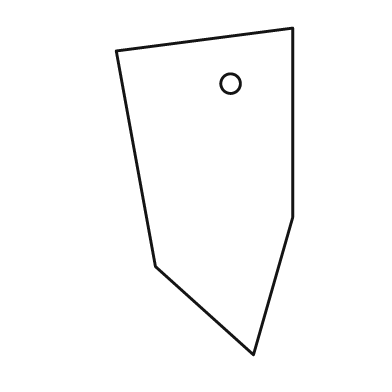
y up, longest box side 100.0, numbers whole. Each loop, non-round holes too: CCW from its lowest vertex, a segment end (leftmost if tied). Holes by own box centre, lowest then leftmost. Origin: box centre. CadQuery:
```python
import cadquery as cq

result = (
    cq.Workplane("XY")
    .moveTo(15.0, -50.0)
    .lineTo(27.0, -8.0)
    .lineTo(27.0, 50.0)
    .lineTo(-27.0, 43.0)
    .lineTo(-15.0, -23.0)
    .close()
    .moveTo(8.0, 33.0)
    .circle(3.0)
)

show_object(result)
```